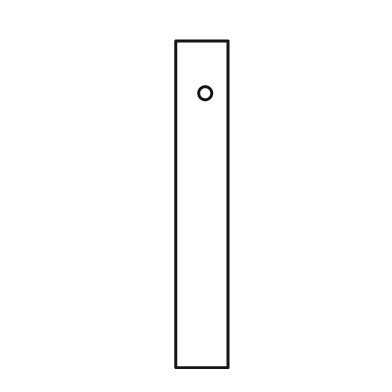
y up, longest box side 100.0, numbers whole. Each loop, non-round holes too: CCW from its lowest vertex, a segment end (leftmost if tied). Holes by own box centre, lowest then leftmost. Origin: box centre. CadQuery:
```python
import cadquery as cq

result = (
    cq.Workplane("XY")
    .moveTo(-8.0, -50.0)
    .lineTo(8.0, -50.0)
    .lineTo(8.0, 50.0)
    .lineTo(-8.0, 50.0)
    .close()
    .moveTo(1.0, 34.0)
    .circle(2.0)
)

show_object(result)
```